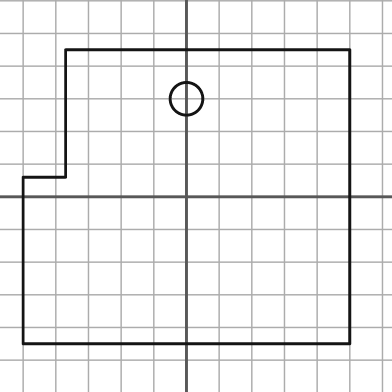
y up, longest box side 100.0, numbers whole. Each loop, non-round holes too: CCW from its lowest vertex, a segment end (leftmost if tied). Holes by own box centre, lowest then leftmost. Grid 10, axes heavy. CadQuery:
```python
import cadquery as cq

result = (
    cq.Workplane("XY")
    .moveTo(-50.0, -45.0)
    .lineTo(50.0, -45.0)
    .lineTo(50.0, 45.0)
    .lineTo(-37.0, 45.0)
    .lineTo(-37.0, 6.0)
    .lineTo(-50.0, 6.0)
    .close()
    .moveTo(0.0, 30.0)
    .circle(5.0)
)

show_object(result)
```